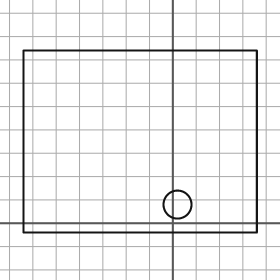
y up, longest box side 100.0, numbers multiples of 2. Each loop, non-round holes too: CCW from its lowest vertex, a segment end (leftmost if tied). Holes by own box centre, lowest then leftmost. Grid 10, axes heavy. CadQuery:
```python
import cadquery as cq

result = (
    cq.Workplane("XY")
    .moveTo(-64.0, -4.0)
    .lineTo(36.0, -4.0)
    .lineTo(36.0, 74.0)
    .lineTo(-64.0, 74.0)
    .close()
    .moveTo(2.0, 8.0)
    .circle(6.0)
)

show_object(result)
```